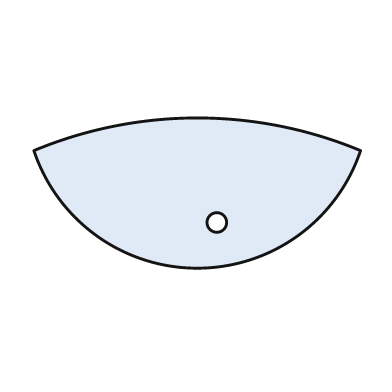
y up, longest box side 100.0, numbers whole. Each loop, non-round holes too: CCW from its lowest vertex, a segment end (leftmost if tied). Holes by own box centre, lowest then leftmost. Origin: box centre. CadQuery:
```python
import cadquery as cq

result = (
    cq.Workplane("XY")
    .moveTo(-50.0, 13.0)
    .threePointArc((0.0, -23.0), (50.0, 13.0))
    .threePointArc((0.0, 23.0), (-50.0, 13.0))
    .close()
    .moveTo(6.0, -9.0)
    .circle(3.0)
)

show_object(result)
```